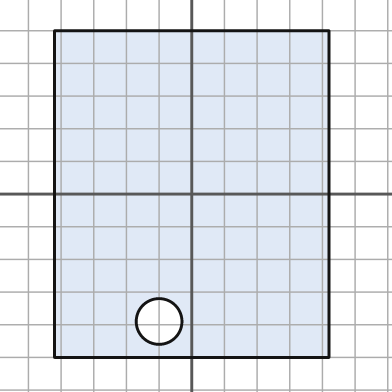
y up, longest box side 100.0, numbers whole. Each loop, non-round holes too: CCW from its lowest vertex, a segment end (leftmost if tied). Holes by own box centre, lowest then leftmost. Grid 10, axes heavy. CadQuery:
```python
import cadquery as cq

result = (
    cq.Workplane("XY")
    .moveTo(-42.0, -50.0)
    .lineTo(42.0, -50.0)
    .lineTo(42.0, 50.0)
    .lineTo(-42.0, 50.0)
    .close()
    .moveTo(-10.0, -39.0)
    .circle(7.0)
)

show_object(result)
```